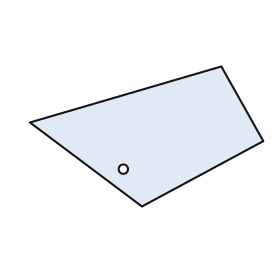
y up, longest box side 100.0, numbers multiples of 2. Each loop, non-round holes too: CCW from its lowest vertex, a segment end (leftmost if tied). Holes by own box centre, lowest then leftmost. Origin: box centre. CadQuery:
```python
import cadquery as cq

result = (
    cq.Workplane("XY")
    .moveTo(-2.0, -30.0)
    .lineTo(50.0, -2.0)
    .lineTo(32.0, 30.0)
    .lineTo(-50.0, 6.0)
    .close()
    .moveTo(-10.0, -14.0)
    .circle(2.0)
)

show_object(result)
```